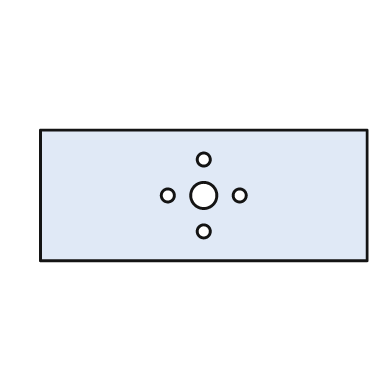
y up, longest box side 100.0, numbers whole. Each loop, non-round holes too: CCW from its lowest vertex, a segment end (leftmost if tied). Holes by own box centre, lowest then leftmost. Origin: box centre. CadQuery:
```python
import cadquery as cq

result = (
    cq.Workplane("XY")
    .moveTo(-50.0, -20.0)
    .lineTo(50.0, -20.0)
    .lineTo(50.0, 20.0)
    .lineTo(-50.0, 20.0)
    .close()
    .moveTo(0.0, -11.0)
    .circle(2.0)
    .moveTo(-11.0, 0.0)
    .circle(2.0)
    .moveTo(0.0, 0.0)
    .circle(4.0)
    .moveTo(11.0, 0.0)
    .circle(2.0)
    .moveTo(0.0, 11.0)
    .circle(2.0)
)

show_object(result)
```